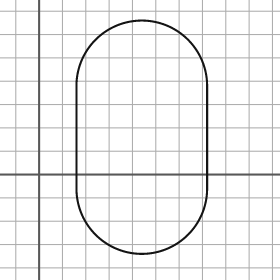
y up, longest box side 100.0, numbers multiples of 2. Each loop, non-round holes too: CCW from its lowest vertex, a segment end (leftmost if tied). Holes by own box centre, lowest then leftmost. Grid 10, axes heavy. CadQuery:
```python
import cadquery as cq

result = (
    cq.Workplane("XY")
    .moveTo(16.0, -6.0)
    .threePointArc((44.0, -34.0), (72.0, -6.0))
    .lineTo(72.0, 38.0)
    .threePointArc((44.0, 66.0), (16.0, 38.0))
    .close()
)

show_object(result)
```